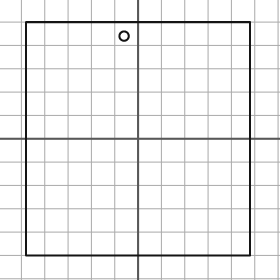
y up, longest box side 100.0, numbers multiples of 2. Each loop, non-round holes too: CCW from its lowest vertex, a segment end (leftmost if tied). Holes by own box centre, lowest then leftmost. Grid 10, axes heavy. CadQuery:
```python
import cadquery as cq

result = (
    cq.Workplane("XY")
    .moveTo(-48.0, -50.0)
    .lineTo(48.0, -50.0)
    .lineTo(48.0, 50.0)
    .lineTo(-48.0, 50.0)
    .close()
    .moveTo(-6.0, 44.0)
    .circle(2.0)
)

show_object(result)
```